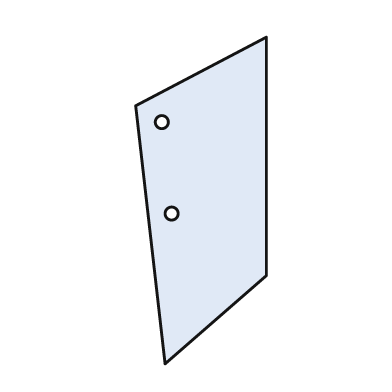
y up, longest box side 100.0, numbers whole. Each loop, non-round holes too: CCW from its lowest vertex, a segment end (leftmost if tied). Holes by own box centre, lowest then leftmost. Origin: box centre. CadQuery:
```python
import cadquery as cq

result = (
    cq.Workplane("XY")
    .moveTo(-11.0, -50.0)
    .lineTo(20.0, -23.0)
    .lineTo(20.0, 50.0)
    .lineTo(-20.0, 29.0)
    .close()
    .moveTo(-9.0, -4.0)
    .circle(2.0)
    .moveTo(-12.0, 24.0)
    .circle(2.0)
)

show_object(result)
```